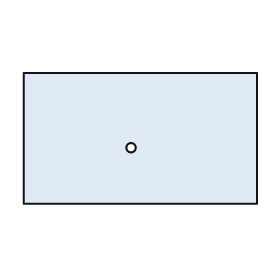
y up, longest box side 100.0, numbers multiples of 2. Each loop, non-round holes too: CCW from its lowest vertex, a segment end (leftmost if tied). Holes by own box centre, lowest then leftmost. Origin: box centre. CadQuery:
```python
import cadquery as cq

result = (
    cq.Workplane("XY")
    .moveTo(-50.0, -28.0)
    .lineTo(50.0, -28.0)
    .lineTo(50.0, 28.0)
    .lineTo(-50.0, 28.0)
    .close()
    .moveTo(-4.0, -4.0)
    .circle(2.0)
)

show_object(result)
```